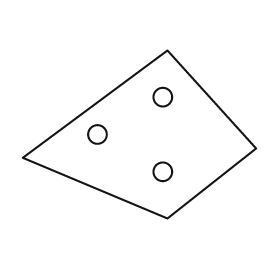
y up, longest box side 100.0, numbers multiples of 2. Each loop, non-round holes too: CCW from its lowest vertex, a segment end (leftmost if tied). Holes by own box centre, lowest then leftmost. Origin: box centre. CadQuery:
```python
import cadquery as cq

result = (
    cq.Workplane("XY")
    .moveTo(12.0, -36.0)
    .lineTo(50.0, -6.0)
    .lineTo(12.0, 36.0)
    .lineTo(-50.0, -10.0)
    .close()
    .moveTo(10.0, -16.0)
    .circle(4.0)
    .moveTo(-18.0, 0.0)
    .circle(4.0)
    .moveTo(10.0, 16.0)
    .circle(4.0)
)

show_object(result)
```